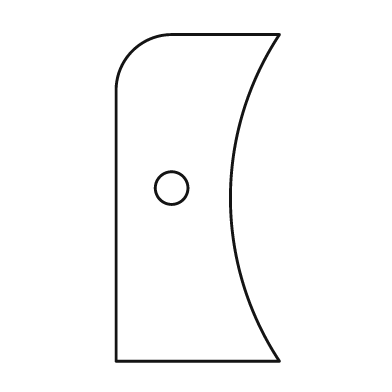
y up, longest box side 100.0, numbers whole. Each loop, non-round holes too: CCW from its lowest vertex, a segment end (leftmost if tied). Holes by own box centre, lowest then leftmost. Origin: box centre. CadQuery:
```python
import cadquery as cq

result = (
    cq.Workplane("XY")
    .moveTo(-25.0, -50.0)
    .lineTo(25.0, -50.0)
    .threePointArc((10.0, 0.0), (25.0, 50.0))
    .lineTo(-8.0, 50.0)
    .threePointArc((-20.0, 45.0), (-25.0, 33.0))
    .close()
    .moveTo(-8.0, 3.0)
    .circle(5.0)
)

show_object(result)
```